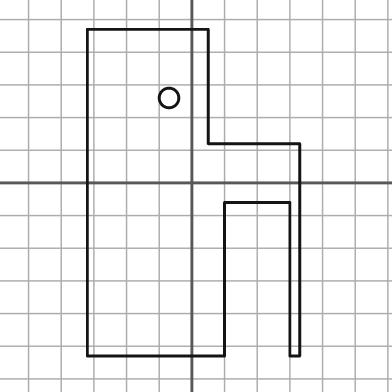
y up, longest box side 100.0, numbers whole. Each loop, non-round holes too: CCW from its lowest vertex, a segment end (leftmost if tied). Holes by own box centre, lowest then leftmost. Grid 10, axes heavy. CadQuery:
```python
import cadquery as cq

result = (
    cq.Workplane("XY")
    .moveTo(-32.0, -53.0)
    .lineTo(10.0, -53.0)
    .lineTo(10.0, -6.0)
    .lineTo(30.0, -6.0)
    .lineTo(30.0, -53.0)
    .lineTo(33.0, -53.0)
    .lineTo(33.0, 12.0)
    .lineTo(5.0, 12.0)
    .lineTo(5.0, 47.0)
    .lineTo(-32.0, 47.0)
    .close()
    .moveTo(-7.0, 26.0)
    .circle(3.0)
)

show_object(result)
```